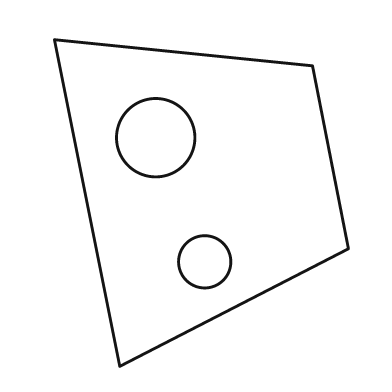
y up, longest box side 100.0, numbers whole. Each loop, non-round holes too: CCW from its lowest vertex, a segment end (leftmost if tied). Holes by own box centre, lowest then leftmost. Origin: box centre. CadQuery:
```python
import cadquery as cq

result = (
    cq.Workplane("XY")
    .moveTo(-25.0, -50.0)
    .lineTo(45.0, -14.0)
    .lineTo(34.0, 42.0)
    .lineTo(-45.0, 50.0)
    .close()
    .moveTo(1.0, -18.0)
    .circle(8.0)
    .moveTo(-14.0, 20.0)
    .circle(12.0)
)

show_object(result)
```